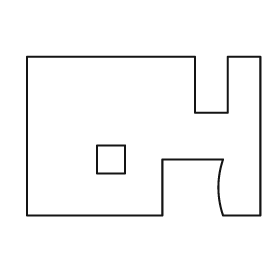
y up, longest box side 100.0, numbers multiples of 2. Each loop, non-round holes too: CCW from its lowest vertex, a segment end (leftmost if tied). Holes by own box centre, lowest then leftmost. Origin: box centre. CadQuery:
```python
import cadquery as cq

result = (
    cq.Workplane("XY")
    .moveTo(-50.0, -34.0)
    .lineTo(8.0, -34.0)
    .lineTo(8.0, -10.0)
    .lineTo(34.0, -10.0)
    .threePointArc((32.0, -22.0), (34.0, -34.0))
    .lineTo(50.0, -34.0)
    .lineTo(50.0, 34.0)
    .lineTo(36.0, 34.0)
    .lineTo(36.0, 10.0)
    .lineTo(22.0, 10.0)
    .lineTo(22.0, 34.0)
    .lineTo(-50.0, 34.0)
    .close()
    .moveTo(-20.0, -16.0)
    .lineTo(-8.0, -16.0)
    .lineTo(-8.0, -4.0)
    .lineTo(-20.0, -4.0)
    .close()
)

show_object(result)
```